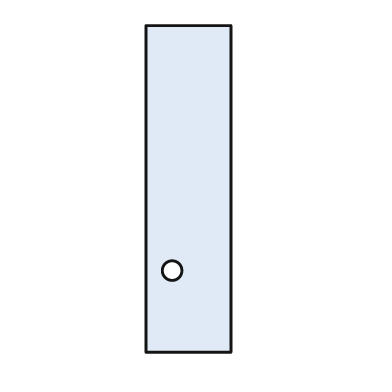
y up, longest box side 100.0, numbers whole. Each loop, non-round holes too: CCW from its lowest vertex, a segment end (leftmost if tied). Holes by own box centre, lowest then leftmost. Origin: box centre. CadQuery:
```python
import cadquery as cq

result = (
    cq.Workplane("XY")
    .moveTo(-13.0, -50.0)
    .lineTo(13.0, -50.0)
    .lineTo(13.0, 50.0)
    .lineTo(-13.0, 50.0)
    .close()
    .moveTo(-5.0, -25.0)
    .circle(3.0)
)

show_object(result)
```